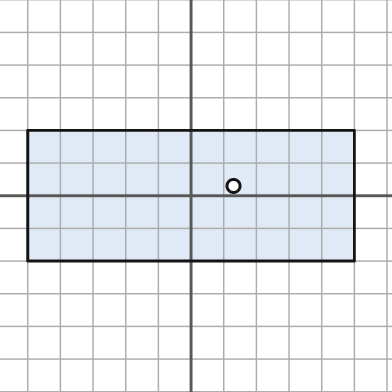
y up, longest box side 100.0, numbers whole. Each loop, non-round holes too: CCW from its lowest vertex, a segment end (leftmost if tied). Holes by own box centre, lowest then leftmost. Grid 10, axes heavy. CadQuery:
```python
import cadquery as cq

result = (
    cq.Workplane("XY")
    .moveTo(-50.0, -20.0)
    .lineTo(50.0, -20.0)
    .lineTo(50.0, 20.0)
    .lineTo(-50.0, 20.0)
    .close()
    .moveTo(13.0, 3.0)
    .circle(2.0)
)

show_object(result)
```